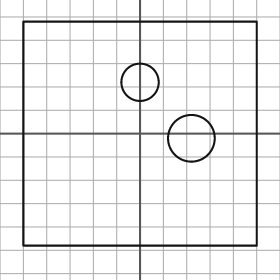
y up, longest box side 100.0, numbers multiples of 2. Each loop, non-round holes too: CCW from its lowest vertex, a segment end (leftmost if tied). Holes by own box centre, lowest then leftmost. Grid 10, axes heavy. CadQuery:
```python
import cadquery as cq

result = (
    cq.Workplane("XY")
    .moveTo(-50.0, -48.0)
    .lineTo(50.0, -48.0)
    .lineTo(50.0, 48.0)
    .lineTo(-50.0, 48.0)
    .close()
    .moveTo(22.0, -2.0)
    .circle(10.0)
    .moveTo(0.0, 22.0)
    .circle(8.0)
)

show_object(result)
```